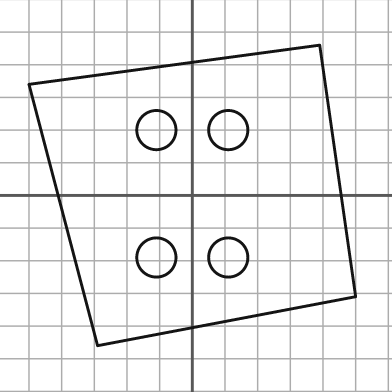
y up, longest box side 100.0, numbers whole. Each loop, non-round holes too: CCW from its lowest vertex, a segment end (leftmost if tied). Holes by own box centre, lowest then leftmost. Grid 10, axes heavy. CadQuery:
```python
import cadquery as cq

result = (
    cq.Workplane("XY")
    .moveTo(-29.0, -46.0)
    .lineTo(50.0, -31.0)
    .lineTo(39.0, 46.0)
    .lineTo(-50.0, 34.0)
    .close()
    .moveTo(-11.0, -19.0)
    .circle(6.0)
    .moveTo(11.0, -19.0)
    .circle(6.0)
    .moveTo(-11.0, 20.0)
    .circle(6.0)
    .moveTo(11.0, 20.0)
    .circle(6.0)
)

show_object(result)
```